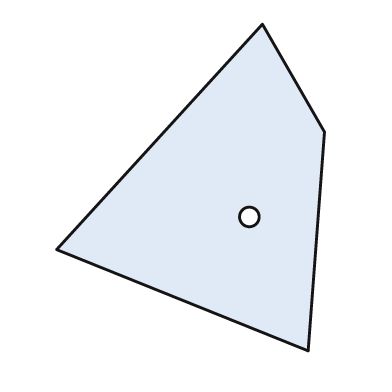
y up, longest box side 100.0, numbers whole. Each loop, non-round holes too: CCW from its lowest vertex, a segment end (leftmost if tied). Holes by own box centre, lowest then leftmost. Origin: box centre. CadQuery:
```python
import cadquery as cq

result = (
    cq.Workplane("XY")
    .moveTo(36.0, -50.0)
    .lineTo(41.0, 17.0)
    .lineTo(22.0, 50.0)
    .lineTo(-41.0, -19.0)
    .close()
    .moveTo(18.0, -9.0)
    .circle(3.0)
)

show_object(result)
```